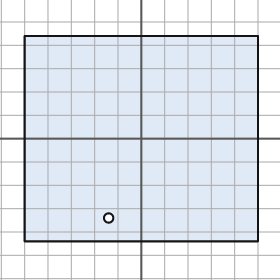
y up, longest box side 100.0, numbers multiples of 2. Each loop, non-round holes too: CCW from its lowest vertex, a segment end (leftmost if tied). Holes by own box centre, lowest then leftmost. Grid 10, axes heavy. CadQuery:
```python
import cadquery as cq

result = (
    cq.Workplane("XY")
    .moveTo(-50.0, -44.0)
    .lineTo(50.0, -44.0)
    .lineTo(50.0, 44.0)
    .lineTo(-50.0, 44.0)
    .close()
    .moveTo(-14.0, -34.0)
    .circle(2.0)
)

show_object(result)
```